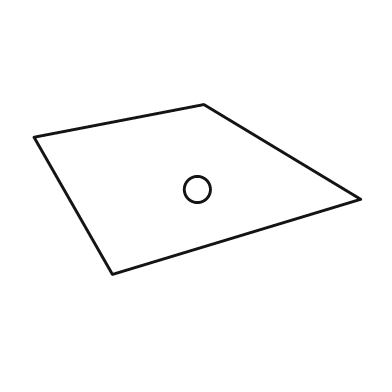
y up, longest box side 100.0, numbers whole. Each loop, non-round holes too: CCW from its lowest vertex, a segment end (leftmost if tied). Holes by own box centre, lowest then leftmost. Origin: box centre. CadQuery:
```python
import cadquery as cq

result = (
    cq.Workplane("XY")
    .moveTo(-26.0, -26.0)
    .lineTo(50.0, -3.0)
    .lineTo(2.0, 26.0)
    .lineTo(-50.0, 16.0)
    .close()
    .moveTo(0.0, 0.0)
    .circle(4.0)
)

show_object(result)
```